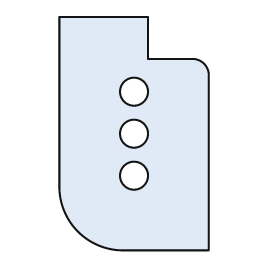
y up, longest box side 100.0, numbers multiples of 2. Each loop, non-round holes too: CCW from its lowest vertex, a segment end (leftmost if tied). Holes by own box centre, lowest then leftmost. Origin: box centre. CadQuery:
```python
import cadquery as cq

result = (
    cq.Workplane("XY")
    .moveTo(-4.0, -50.0)
    .lineTo(32.0, -50.0)
    .lineTo(32.0, 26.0)
    .threePointArc((30.0, 30.0), (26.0, 32.0))
    .lineTo(6.0, 32.0)
    .lineTo(6.0, 50.0)
    .lineTo(-32.0, 50.0)
    .lineTo(-32.0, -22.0)
    .threePointArc((-24.0, -42.0), (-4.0, -50.0))
    .close()
    .moveTo(0.0, -18.0)
    .circle(6.0)
    .moveTo(0.0, 0.0)
    .circle(6.0)
    .moveTo(0.0, 18.0)
    .circle(6.0)
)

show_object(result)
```